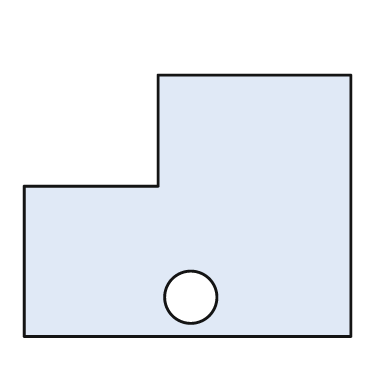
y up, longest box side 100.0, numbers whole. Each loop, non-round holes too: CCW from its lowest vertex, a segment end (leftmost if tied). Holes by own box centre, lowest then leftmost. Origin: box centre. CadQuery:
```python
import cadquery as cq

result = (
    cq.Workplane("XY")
    .moveTo(-50.0, -40.0)
    .lineTo(50.0, -40.0)
    .lineTo(50.0, 40.0)
    .lineTo(-9.0, 40.0)
    .lineTo(-9.0, 6.0)
    .lineTo(-50.0, 6.0)
    .close()
    .moveTo(1.0, -28.0)
    .circle(8.0)
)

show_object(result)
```